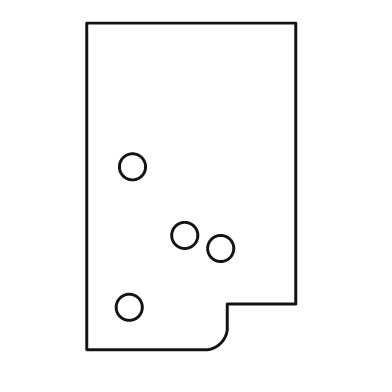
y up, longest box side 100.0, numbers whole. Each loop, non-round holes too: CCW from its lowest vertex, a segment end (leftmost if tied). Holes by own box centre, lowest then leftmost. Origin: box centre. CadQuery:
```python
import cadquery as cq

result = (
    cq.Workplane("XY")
    .moveTo(-32.0, -50.0)
    .lineTo(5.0, -50.0)
    .threePointArc((9.0, -48.0), (11.0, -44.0))
    .lineTo(11.0, -36.0)
    .lineTo(32.0, -36.0)
    .lineTo(32.0, 50.0)
    .lineTo(-32.0, 50.0)
    .close()
    .moveTo(-19.0, -37.0)
    .circle(4.0)
    .moveTo(9.0, -19.0)
    .circle(4.0)
    .moveTo(-2.0, -15.0)
    .circle(4.0)
    .moveTo(-18.0, 6.0)
    .circle(4.0)
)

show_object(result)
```